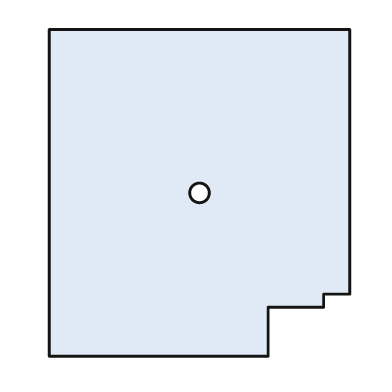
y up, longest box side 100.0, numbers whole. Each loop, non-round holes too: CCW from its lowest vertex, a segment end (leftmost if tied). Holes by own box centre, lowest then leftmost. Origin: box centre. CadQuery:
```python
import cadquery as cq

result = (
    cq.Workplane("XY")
    .moveTo(-46.0, -50.0)
    .lineTo(21.0, -50.0)
    .lineTo(21.0, -35.0)
    .lineTo(38.0, -35.0)
    .lineTo(38.0, -31.0)
    .lineTo(46.0, -31.0)
    .lineTo(46.0, 50.0)
    .lineTo(-46.0, 50.0)
    .close()
    .moveTo(0.0, 0.0)
    .circle(3.0)
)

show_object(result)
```